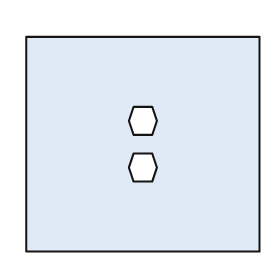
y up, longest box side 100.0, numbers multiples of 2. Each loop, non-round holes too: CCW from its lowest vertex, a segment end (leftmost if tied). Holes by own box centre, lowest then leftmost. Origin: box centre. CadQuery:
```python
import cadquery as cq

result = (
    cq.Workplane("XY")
    .moveTo(-50.0, -46.0)
    .lineTo(50.0, -46.0)
    .lineTo(50.0, 46.0)
    .lineTo(-50.0, 46.0)
    .close()
    .moveTo(-4.0, -16.0)
    .lineTo(4.0, -16.0)
    .lineTo(6.0, -10.0)
    .lineTo(4.0, -4.0)
    .lineTo(-4.0, -4.0)
    .lineTo(-6.0, -10.0)
    .close()
    .moveTo(-4.0, 4.0)
    .lineTo(4.0, 4.0)
    .lineTo(6.0, 10.0)
    .lineTo(4.0, 16.0)
    .lineTo(-4.0, 16.0)
    .lineTo(-6.0, 10.0)
    .close()
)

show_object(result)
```